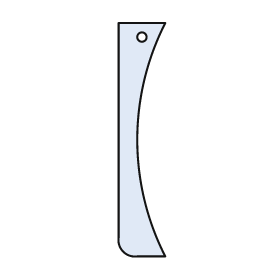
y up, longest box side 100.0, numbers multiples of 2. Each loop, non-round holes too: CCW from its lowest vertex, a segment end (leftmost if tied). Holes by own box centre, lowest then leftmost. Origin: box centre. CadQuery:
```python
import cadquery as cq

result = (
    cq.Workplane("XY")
    .moveTo(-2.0, -50.0)
    .lineTo(10.0, -50.0)
    .threePointArc((-2.0, 0.0), (10.0, 50.0))
    .lineTo(-10.0, 50.0)
    .lineTo(-10.0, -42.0)
    .threePointArc((-8.0, -48.0), (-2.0, -50.0))
    .close()
    .moveTo(0.0, 44.0)
    .circle(2.0)
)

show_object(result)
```